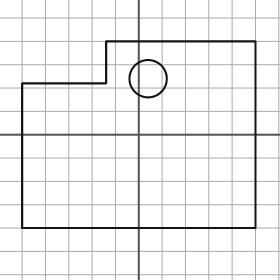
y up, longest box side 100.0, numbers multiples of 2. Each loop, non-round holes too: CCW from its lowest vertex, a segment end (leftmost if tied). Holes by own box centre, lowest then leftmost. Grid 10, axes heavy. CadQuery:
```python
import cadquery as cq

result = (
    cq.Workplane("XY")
    .moveTo(-50.0, -40.0)
    .lineTo(50.0, -40.0)
    .lineTo(50.0, 40.0)
    .lineTo(-14.0, 40.0)
    .lineTo(-14.0, 22.0)
    .lineTo(-50.0, 22.0)
    .close()
    .moveTo(4.0, 24.0)
    .circle(8.0)
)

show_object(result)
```